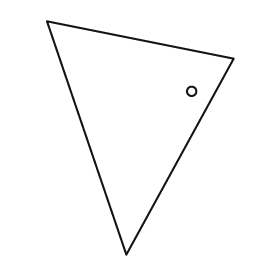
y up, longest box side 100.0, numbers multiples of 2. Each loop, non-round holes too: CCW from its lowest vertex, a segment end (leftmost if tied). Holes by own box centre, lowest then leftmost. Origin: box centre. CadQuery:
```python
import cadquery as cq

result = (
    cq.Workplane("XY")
    .moveTo(-6.0, -50.0)
    .lineTo(40.0, 34.0)
    .lineTo(-40.0, 50.0)
    .close()
    .moveTo(22.0, 20.0)
    .circle(2.0)
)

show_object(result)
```